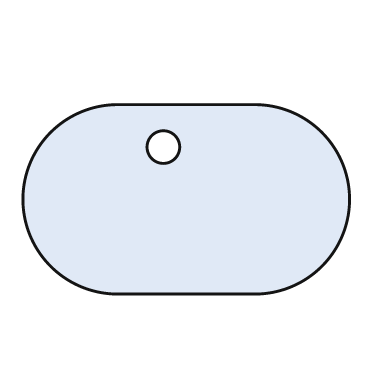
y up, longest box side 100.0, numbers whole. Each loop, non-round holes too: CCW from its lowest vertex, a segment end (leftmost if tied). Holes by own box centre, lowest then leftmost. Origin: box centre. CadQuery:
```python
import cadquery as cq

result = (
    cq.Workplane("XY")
    .moveTo(-21.0, -29.0)
    .lineTo(21.0, -29.0)
    .threePointArc((50.0, 0.0), (21.0, 29.0))
    .lineTo(-21.0, 29.0)
    .threePointArc((-50.0, 0.0), (-21.0, -29.0))
    .close()
    .moveTo(-7.0, 16.0)
    .circle(5.0)
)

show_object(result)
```